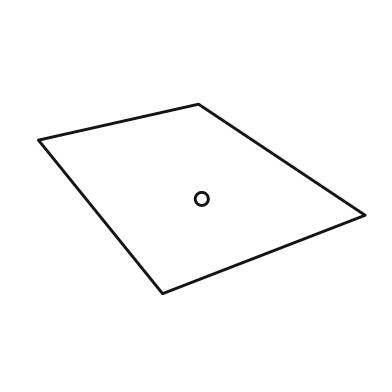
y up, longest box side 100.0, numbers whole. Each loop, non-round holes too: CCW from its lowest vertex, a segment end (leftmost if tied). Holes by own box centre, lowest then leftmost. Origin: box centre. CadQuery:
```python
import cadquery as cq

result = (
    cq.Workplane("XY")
    .moveTo(-12.0, -29.0)
    .lineTo(50.0, -5.0)
    .lineTo(-1.0, 29.0)
    .lineTo(-50.0, 18.0)
    .close()
    .moveTo(0.0, 0.0)
    .circle(2.0)
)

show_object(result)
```